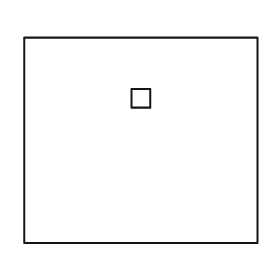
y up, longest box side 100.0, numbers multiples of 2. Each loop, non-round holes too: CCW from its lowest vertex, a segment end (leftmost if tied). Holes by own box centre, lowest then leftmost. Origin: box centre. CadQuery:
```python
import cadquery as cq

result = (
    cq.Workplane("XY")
    .moveTo(-50.0, -44.0)
    .lineTo(50.0, -44.0)
    .lineTo(50.0, 44.0)
    .lineTo(-50.0, 44.0)
    .close()
    .moveTo(-4.0, 14.0)
    .lineTo(4.0, 14.0)
    .lineTo(4.0, 22.0)
    .lineTo(-4.0, 22.0)
    .close()
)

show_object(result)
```